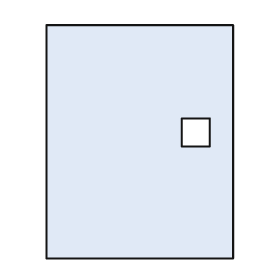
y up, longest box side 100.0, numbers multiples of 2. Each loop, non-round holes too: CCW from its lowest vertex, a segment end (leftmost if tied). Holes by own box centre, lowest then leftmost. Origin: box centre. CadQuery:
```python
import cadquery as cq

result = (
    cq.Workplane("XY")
    .moveTo(-40.0, -50.0)
    .lineTo(40.0, -50.0)
    .lineTo(40.0, 50.0)
    .lineTo(-40.0, 50.0)
    .close()
    .moveTo(18.0, -2.0)
    .lineTo(30.0, -2.0)
    .lineTo(30.0, 10.0)
    .lineTo(18.0, 10.0)
    .close()
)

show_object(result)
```